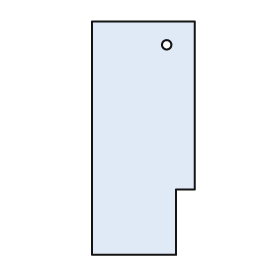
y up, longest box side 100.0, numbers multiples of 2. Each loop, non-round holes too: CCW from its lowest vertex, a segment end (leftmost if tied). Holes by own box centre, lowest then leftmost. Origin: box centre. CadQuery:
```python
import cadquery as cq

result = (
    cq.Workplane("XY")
    .moveTo(-22.0, -50.0)
    .lineTo(14.0, -50.0)
    .lineTo(14.0, -22.0)
    .lineTo(22.0, -22.0)
    .lineTo(22.0, 50.0)
    .lineTo(-22.0, 50.0)
    .close()
    .moveTo(10.0, 40.0)
    .circle(2.0)
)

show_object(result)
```